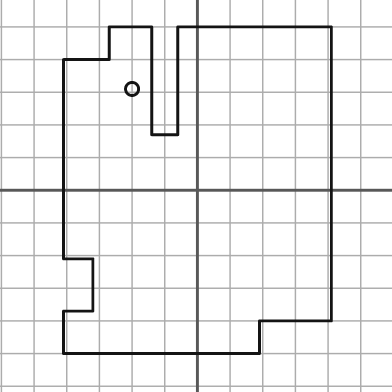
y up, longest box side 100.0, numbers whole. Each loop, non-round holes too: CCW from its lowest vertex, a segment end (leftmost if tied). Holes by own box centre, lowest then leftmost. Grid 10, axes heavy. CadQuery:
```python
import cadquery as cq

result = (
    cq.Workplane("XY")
    .moveTo(-41.0, -50.0)
    .lineTo(19.0, -50.0)
    .lineTo(19.0, -40.0)
    .lineTo(41.0, -40.0)
    .lineTo(41.0, 50.0)
    .lineTo(-6.0, 50.0)
    .lineTo(-6.0, 17.0)
    .lineTo(-14.0, 17.0)
    .lineTo(-14.0, 50.0)
    .lineTo(-27.0, 50.0)
    .lineTo(-27.0, 40.0)
    .lineTo(-41.0, 40.0)
    .lineTo(-41.0, -21.0)
    .lineTo(-32.0, -21.0)
    .lineTo(-32.0, -37.0)
    .lineTo(-41.0, -37.0)
    .close()
    .moveTo(-20.0, 31.0)
    .circle(2.0)
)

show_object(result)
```